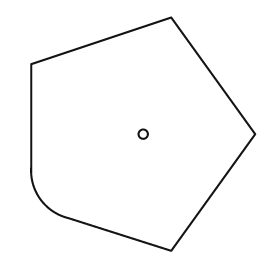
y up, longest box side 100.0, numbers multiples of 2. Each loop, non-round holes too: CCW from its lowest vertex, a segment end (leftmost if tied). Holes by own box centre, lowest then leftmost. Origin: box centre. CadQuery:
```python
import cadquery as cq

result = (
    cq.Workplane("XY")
    .moveTo(12.0, -50.0)
    .lineTo(48.0, 0.0)
    .lineTo(12.0, 50.0)
    .lineTo(-48.0, 30.0)
    .lineTo(-48.0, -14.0)
    .threePointArc((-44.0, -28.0), (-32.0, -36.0))
    .close()
    .moveTo(0.0, 0.0)
    .circle(2.0)
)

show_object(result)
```